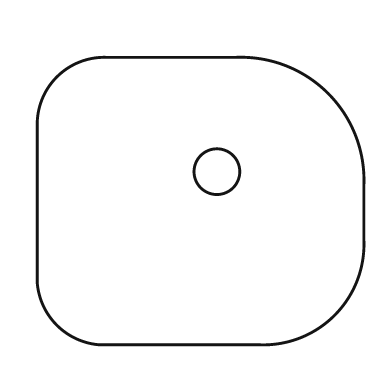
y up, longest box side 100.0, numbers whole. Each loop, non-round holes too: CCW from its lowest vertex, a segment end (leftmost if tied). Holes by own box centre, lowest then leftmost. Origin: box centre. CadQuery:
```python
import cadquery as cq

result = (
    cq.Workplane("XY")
    .moveTo(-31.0, -44.0)
    .lineTo(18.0, -44.0)
    .threePointArc((41.0, -35.0), (50.0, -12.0))
    .lineTo(50.0, 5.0)
    .threePointArc((39.0, 33.0), (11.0, 44.0))
    .lineTo(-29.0, 44.0)
    .threePointArc((-44.0, 38.0), (-50.0, 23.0))
    .lineTo(-50.0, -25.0)
    .threePointArc((-44.0, -38.0), (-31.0, -44.0))
    .close()
    .moveTo(5.0, 9.0)
    .circle(7.0)
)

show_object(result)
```